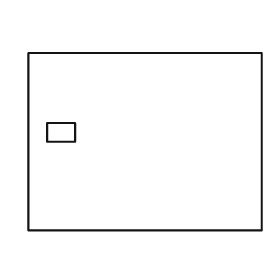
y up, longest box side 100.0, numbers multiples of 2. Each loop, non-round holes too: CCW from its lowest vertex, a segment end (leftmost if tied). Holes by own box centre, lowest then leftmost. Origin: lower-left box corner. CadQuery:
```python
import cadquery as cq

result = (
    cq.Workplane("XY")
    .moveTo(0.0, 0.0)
    .lineTo(100.0, 0.0)
    .lineTo(100.0, 76.0)
    .lineTo(0.0, 76.0)
    .close()
    .moveTo(8.0, 38.0)
    .lineTo(20.0, 38.0)
    .lineTo(20.0, 46.0)
    .lineTo(8.0, 46.0)
    .close()
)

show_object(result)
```